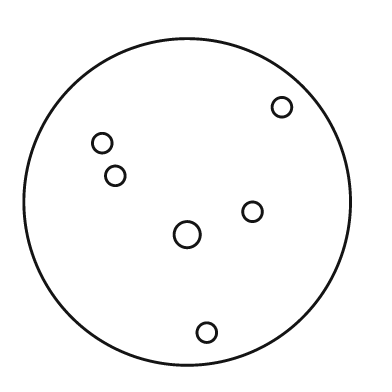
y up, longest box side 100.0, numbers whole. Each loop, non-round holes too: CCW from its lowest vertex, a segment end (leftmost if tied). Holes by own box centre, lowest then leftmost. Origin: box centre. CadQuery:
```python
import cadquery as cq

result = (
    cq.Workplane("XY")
    .moveTo(0.0, 0.0)
    .circle(50.0)
    .moveTo(6.0, -40.0)
    .circle(3.0)
    .moveTo(0.0, -10.0)
    .circle(4.0)
    .moveTo(20.0, -3.0)
    .circle(3.0)
    .moveTo(-22.0, 8.0)
    .circle(3.0)
    .moveTo(-26.0, 18.0)
    .circle(3.0)
    .moveTo(29.0, 29.0)
    .circle(3.0)
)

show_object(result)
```